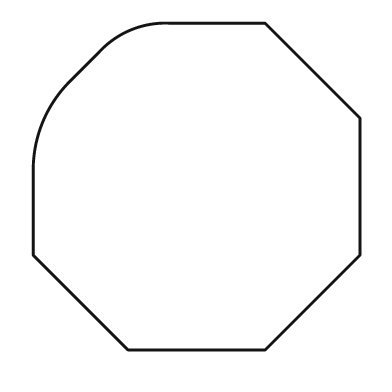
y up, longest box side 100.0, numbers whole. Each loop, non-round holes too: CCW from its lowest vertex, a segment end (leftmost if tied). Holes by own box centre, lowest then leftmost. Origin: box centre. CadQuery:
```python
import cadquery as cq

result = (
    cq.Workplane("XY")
    .moveTo(-21.0, -50.0)
    .lineTo(21.0, -50.0)
    .lineTo(50.0, -21.0)
    .lineTo(50.0, 21.0)
    .lineTo(21.0, 50.0)
    .lineTo(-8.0, 50.0)
    .threePointArc((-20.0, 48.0), (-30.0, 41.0))
    .lineTo(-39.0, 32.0)
    .threePointArc((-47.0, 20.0), (-50.0, 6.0))
    .lineTo(-50.0, -21.0)
    .close()
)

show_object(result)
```